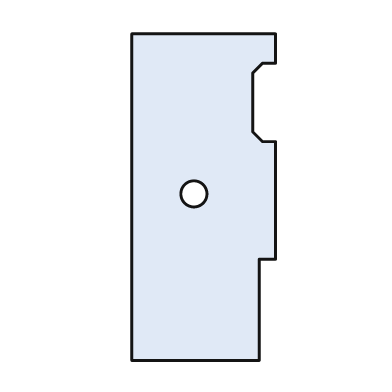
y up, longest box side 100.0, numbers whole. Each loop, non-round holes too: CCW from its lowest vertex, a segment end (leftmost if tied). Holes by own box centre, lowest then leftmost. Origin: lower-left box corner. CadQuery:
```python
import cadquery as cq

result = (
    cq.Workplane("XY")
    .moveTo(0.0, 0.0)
    .lineTo(39.0, 0.0)
    .lineTo(39.0, 31.0)
    .lineTo(44.0, 31.0)
    .lineTo(44.0, 67.0)
    .lineTo(40.0, 67.0)
    .lineTo(37.0, 70.0)
    .lineTo(37.0, 88.0)
    .lineTo(40.0, 91.0)
    .lineTo(44.0, 91.0)
    .lineTo(44.0, 100.0)
    .lineTo(0.0, 100.0)
    .close()
    .moveTo(19.0, 51.0)
    .circle(4.0)
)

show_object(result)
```